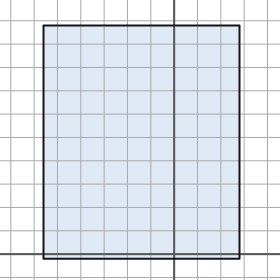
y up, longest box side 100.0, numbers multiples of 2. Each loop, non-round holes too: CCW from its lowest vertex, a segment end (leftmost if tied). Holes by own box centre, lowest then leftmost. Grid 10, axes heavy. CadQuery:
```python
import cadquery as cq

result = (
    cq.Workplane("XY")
    .moveTo(-56.0, -2.0)
    .lineTo(28.0, -2.0)
    .lineTo(28.0, 98.0)
    .lineTo(-56.0, 98.0)
    .close()
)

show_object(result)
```